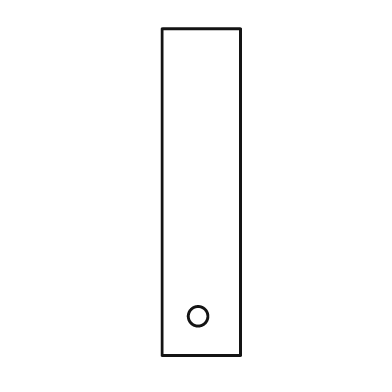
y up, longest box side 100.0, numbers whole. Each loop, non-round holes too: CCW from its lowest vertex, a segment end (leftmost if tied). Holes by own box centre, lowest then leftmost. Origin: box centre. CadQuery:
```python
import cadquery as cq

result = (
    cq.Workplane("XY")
    .moveTo(-12.0, -50.0)
    .lineTo(12.0, -50.0)
    .lineTo(12.0, 50.0)
    .lineTo(-12.0, 50.0)
    .close()
    .moveTo(-1.0, -38.0)
    .circle(3.0)
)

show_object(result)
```